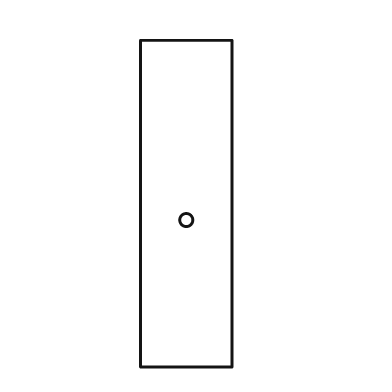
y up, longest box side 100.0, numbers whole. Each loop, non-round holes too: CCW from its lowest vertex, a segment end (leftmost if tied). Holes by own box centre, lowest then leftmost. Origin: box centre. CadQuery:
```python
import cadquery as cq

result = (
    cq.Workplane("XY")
    .moveTo(-14.0, -50.0)
    .lineTo(14.0, -50.0)
    .lineTo(14.0, 50.0)
    .lineTo(-14.0, 50.0)
    .close()
    .moveTo(0.0, -5.0)
    .circle(2.0)
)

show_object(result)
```